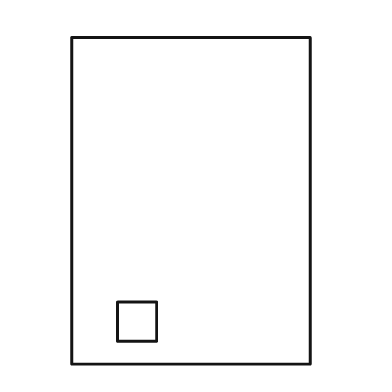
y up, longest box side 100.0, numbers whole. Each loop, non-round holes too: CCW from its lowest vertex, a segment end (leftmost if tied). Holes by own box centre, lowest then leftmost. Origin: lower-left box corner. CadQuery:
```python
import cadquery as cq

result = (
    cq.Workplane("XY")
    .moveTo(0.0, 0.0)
    .lineTo(73.0, 0.0)
    .lineTo(73.0, 100.0)
    .lineTo(0.0, 100.0)
    .close()
    .moveTo(14.0, 7.0)
    .lineTo(26.0, 7.0)
    .lineTo(26.0, 19.0)
    .lineTo(14.0, 19.0)
    .close()
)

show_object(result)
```